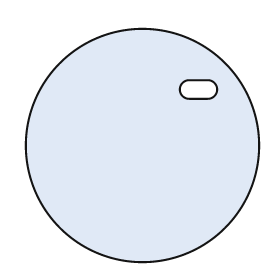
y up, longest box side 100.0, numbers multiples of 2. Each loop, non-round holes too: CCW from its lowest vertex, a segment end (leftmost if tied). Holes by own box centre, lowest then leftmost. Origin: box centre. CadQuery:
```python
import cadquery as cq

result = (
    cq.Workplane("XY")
    .moveTo(0.0, 0.0)
    .circle(50.0)
    .moveTo(20.0, 20.0)
    .lineTo(28.0, 20.0)
    .threePointArc((32.0, 24.0), (28.0, 28.0))
    .lineTo(20.0, 28.0)
    .threePointArc((16.0, 24.0), (20.0, 20.0))
    .close()
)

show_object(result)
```